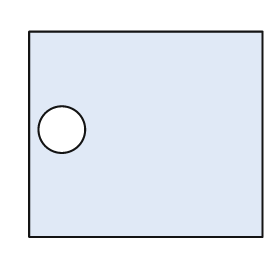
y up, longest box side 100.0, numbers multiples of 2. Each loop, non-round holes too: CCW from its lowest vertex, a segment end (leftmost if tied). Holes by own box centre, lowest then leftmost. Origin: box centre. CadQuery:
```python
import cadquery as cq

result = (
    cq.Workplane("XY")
    .moveTo(-50.0, -44.0)
    .lineTo(50.0, -44.0)
    .lineTo(50.0, 44.0)
    .lineTo(-50.0, 44.0)
    .close()
    .moveTo(-36.0, 2.0)
    .circle(10.0)
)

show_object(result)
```